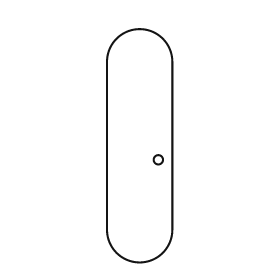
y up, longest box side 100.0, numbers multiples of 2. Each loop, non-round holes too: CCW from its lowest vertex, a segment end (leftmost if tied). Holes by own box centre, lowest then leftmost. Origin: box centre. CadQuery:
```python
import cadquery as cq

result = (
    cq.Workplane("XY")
    .moveTo(-14.0, -36.0)
    .threePointArc((0.0, -50.0), (14.0, -36.0))
    .lineTo(14.0, 36.0)
    .threePointArc((0.0, 50.0), (-14.0, 36.0))
    .close()
    .moveTo(8.0, -6.0)
    .circle(2.0)
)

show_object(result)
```